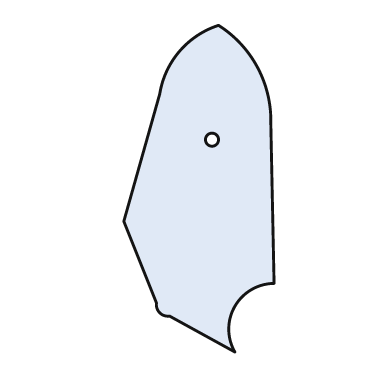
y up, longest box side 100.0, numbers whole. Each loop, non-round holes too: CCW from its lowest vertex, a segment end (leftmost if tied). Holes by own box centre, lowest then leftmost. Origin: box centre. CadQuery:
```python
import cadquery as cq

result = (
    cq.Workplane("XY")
    .moveTo(11.0, -50.0)
    .threePointArc((11.0, -36.0), (23.0, -29.0))
    .lineTo(22.0, 20.0)
    .threePointArc((18.0, 37.0), (6.0, 50.0))
    .threePointArc((-6.0, 42.0), (-12.0, 29.0))
    .lineTo(-23.0, -10.0)
    .lineTo(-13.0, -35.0)
    .threePointArc((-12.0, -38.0), (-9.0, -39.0))
    .close()
    .moveTo(4.0, 15.0)
    .circle(2.0)
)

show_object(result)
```